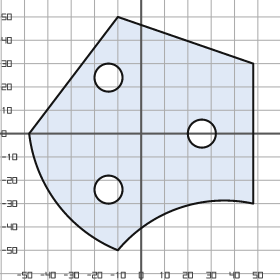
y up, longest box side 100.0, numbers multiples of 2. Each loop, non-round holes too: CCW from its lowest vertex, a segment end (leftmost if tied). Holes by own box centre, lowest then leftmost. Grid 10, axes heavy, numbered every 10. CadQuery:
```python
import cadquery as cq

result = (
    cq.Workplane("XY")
    .moveTo(-10.0, -50.0)
    .threePointArc((16.0, -32.0), (48.0, -30.0))
    .lineTo(48.0, 30.0)
    .lineTo(-10.0, 50.0)
    .lineTo(-48.0, 0.0)
    .threePointArc((-36.0, -30.0), (-10.0, -50.0))
    .close()
    .moveTo(-14.0, -24.0)
    .circle(6.0)
    .moveTo(26.0, 0.0)
    .circle(6.0)
    .moveTo(-14.0, 24.0)
    .circle(6.0)
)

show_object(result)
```